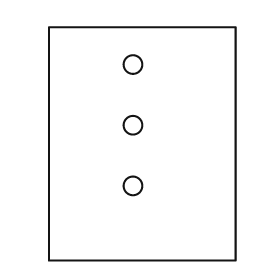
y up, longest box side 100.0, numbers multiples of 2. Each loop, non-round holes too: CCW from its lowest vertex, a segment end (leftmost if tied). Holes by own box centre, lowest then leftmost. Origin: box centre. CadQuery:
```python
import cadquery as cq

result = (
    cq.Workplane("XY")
    .moveTo(-40.0, -50.0)
    .lineTo(40.0, -50.0)
    .lineTo(40.0, 50.0)
    .lineTo(-40.0, 50.0)
    .close()
    .moveTo(-4.0, -18.0)
    .circle(4.0)
    .moveTo(-4.0, 8.0)
    .circle(4.0)
    .moveTo(-4.0, 34.0)
    .circle(4.0)
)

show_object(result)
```